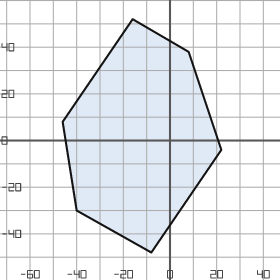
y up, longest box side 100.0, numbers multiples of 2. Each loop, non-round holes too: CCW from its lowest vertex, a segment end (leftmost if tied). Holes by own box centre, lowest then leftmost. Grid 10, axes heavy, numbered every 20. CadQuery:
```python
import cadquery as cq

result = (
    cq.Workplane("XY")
    .moveTo(-8.0, -48.0)
    .lineTo(22.0, -4.0)
    .lineTo(8.0, 38.0)
    .lineTo(-16.0, 52.0)
    .lineTo(-46.0, 8.0)
    .lineTo(-40.0, -30.0)
    .close()
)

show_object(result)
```